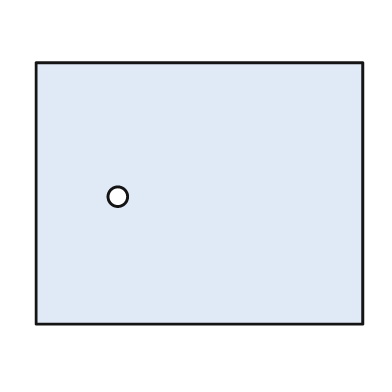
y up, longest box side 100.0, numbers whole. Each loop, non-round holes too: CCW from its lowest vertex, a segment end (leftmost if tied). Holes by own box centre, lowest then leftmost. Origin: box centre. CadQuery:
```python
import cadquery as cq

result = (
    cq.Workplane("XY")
    .moveTo(-50.0, -40.0)
    .lineTo(50.0, -40.0)
    .lineTo(50.0, 40.0)
    .lineTo(-50.0, 40.0)
    .close()
    .moveTo(-25.0, -1.0)
    .circle(3.0)
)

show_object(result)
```